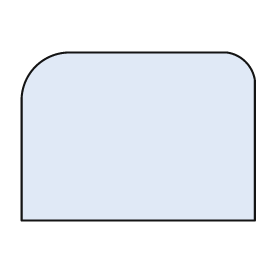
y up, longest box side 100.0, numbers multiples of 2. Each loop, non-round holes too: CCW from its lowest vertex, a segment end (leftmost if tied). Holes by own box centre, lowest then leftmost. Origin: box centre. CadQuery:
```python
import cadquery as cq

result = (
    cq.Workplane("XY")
    .moveTo(-50.0, -36.0)
    .lineTo(50.0, -36.0)
    .lineTo(50.0, 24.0)
    .threePointArc((46.0, 32.0), (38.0, 36.0))
    .lineTo(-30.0, 36.0)
    .threePointArc((-44.0, 30.0), (-50.0, 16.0))
    .close()
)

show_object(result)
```